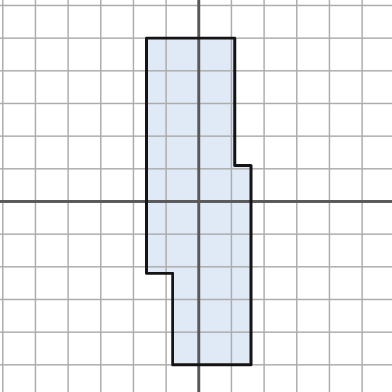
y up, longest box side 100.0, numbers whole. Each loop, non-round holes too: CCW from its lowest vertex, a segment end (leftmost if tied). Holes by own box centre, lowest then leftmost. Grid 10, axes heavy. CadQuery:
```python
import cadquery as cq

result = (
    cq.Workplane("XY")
    .moveTo(-8.0, -50.0)
    .lineTo(16.0, -50.0)
    .lineTo(16.0, 11.0)
    .lineTo(11.0, 11.0)
    .lineTo(11.0, 50.0)
    .lineTo(-16.0, 50.0)
    .lineTo(-16.0, -22.0)
    .lineTo(-8.0, -22.0)
    .close()
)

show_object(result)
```